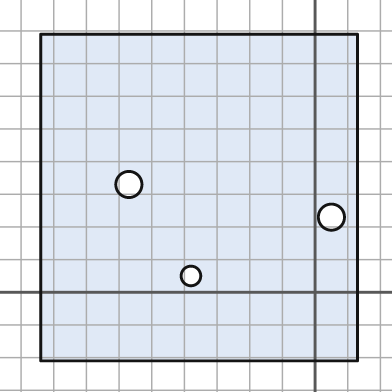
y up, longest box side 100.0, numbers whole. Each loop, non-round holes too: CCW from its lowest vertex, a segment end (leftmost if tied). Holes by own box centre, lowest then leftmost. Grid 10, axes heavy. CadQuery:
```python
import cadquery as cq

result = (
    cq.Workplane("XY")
    .moveTo(-84.0, -21.0)
    .lineTo(13.0, -21.0)
    .lineTo(13.0, 79.0)
    .lineTo(-84.0, 79.0)
    .close()
    .moveTo(-38.0, 5.0)
    .circle(3.0)
    .moveTo(5.0, 23.0)
    .circle(4.0)
    .moveTo(-57.0, 33.0)
    .circle(4.0)
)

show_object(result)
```